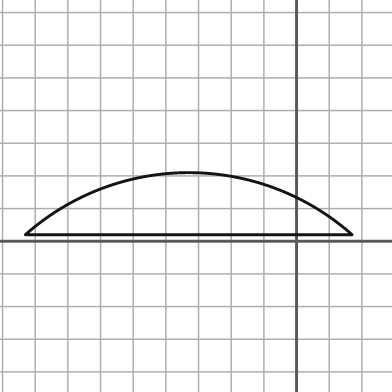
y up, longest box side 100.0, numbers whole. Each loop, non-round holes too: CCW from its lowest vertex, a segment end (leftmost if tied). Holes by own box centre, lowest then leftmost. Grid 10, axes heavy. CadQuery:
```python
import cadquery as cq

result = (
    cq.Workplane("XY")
    .moveTo(-83.0, 2.0)
    .lineTo(17.0, 2.0)
    .threePointArc((-33.0, 21.0), (-83.0, 2.0))
    .close()
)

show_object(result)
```